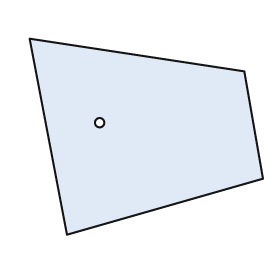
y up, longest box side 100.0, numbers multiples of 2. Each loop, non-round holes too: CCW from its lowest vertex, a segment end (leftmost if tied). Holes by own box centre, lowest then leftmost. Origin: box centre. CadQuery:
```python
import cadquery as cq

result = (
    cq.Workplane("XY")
    .moveTo(-34.0, -42.0)
    .lineTo(50.0, -18.0)
    .lineTo(42.0, 28.0)
    .lineTo(-50.0, 42.0)
    .close()
    .moveTo(-20.0, 6.0)
    .circle(2.0)
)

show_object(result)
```